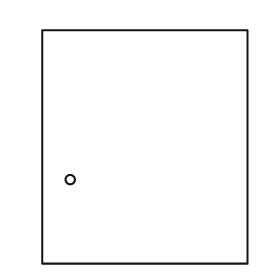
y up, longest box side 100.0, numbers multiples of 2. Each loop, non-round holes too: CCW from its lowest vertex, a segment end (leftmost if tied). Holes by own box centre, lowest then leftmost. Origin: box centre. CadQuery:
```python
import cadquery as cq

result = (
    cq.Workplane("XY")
    .moveTo(-44.0, -50.0)
    .lineTo(44.0, -50.0)
    .lineTo(44.0, 50.0)
    .lineTo(-44.0, 50.0)
    .close()
    .moveTo(-32.0, -14.0)
    .circle(2.0)
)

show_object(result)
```